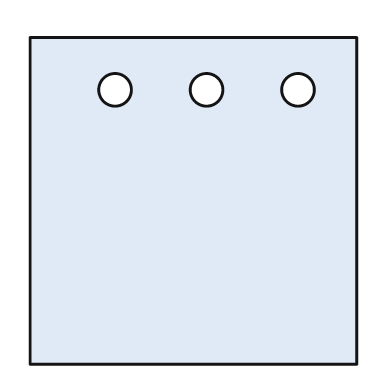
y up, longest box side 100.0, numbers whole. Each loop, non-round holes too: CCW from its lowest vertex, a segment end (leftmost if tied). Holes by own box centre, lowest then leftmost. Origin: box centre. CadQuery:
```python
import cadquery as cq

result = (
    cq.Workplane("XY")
    .moveTo(-50.0, -50.0)
    .lineTo(50.0, -50.0)
    .lineTo(50.0, 50.0)
    .lineTo(-50.0, 50.0)
    .close()
    .moveTo(-24.0, 34.0)
    .circle(5.0)
    .moveTo(4.0, 34.0)
    .circle(5.0)
    .moveTo(32.0, 34.0)
    .circle(5.0)
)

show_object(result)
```